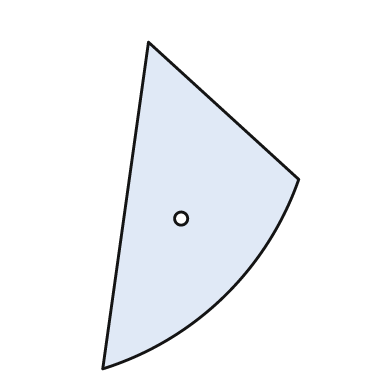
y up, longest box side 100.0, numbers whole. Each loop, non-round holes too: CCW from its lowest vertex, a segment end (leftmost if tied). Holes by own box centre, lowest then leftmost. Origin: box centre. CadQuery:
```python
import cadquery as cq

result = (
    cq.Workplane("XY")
    .moveTo(-30.0, -50.0)
    .threePointArc((7.0, -28.0), (30.0, 8.0))
    .lineTo(-16.0, 50.0)
    .close()
    .moveTo(-6.0, -4.0)
    .circle(2.0)
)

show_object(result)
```